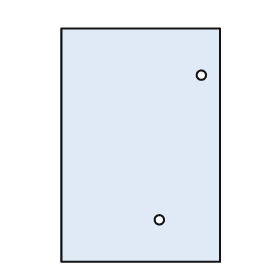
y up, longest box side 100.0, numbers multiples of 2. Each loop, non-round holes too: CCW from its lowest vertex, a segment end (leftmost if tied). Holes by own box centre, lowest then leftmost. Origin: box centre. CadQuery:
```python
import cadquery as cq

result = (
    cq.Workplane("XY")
    .moveTo(-34.0, -50.0)
    .lineTo(34.0, -50.0)
    .lineTo(34.0, 50.0)
    .lineTo(-34.0, 50.0)
    .close()
    .moveTo(8.0, -32.0)
    .circle(2.0)
    .moveTo(26.0, 30.0)
    .circle(2.0)
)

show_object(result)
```